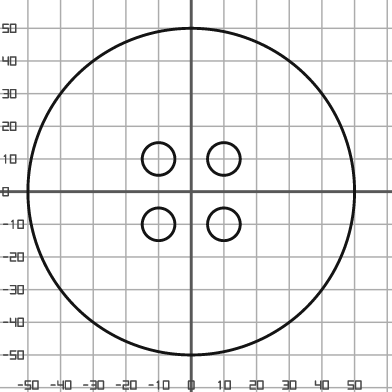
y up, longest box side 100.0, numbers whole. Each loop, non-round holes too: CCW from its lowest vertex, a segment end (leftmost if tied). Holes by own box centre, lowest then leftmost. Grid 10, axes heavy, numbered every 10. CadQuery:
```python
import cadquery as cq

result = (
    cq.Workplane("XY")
    .moveTo(0.0, 0.0)
    .circle(50.0)
    .moveTo(-10.0, -10.0)
    .circle(5.0)
    .moveTo(10.0, -10.0)
    .circle(5.0)
    .moveTo(-10.0, 10.0)
    .circle(5.0)
    .moveTo(10.0, 10.0)
    .circle(5.0)
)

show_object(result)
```